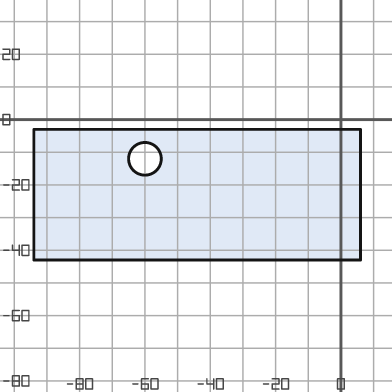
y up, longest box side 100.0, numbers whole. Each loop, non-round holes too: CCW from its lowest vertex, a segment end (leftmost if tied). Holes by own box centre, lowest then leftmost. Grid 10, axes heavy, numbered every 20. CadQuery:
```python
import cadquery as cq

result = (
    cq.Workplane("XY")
    .moveTo(-94.0, -43.0)
    .lineTo(6.0, -43.0)
    .lineTo(6.0, -3.0)
    .lineTo(-94.0, -3.0)
    .close()
    .moveTo(-60.0, -12.0)
    .circle(5.0)
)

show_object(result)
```